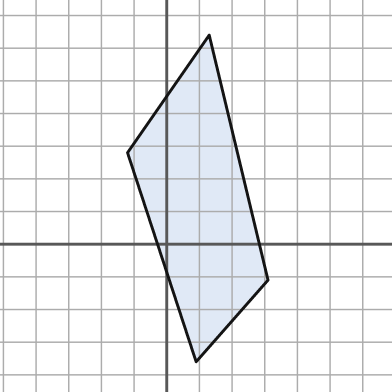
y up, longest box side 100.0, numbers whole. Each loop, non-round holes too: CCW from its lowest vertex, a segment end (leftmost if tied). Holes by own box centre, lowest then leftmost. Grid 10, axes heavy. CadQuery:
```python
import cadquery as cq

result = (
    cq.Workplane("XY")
    .moveTo(9.0, -36.0)
    .lineTo(31.0, -11.0)
    .lineTo(13.0, 64.0)
    .lineTo(-12.0, 28.0)
    .close()
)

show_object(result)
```